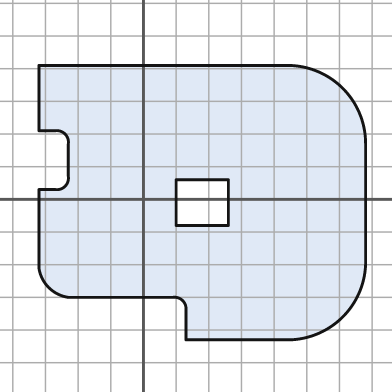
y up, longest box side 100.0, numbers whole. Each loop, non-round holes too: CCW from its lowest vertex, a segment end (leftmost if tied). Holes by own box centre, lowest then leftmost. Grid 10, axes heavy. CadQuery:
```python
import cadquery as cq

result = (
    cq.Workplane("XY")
    .moveTo(13.0, -43.0)
    .lineTo(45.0, -43.0)
    .threePointArc((61.0, -36.0), (68.0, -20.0))
    .lineTo(68.0, 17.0)
    .threePointArc((61.0, 34.0), (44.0, 41.0))
    .lineTo(-32.0, 41.0)
    .lineTo(-32.0, 21.0)
    .lineTo(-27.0, 21.0)
    .threePointArc((-24.0, 20.0), (-23.0, 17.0))
    .lineTo(-23.0, 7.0)
    .threePointArc((-24.0, 4.0), (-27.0, 3.0))
    .lineTo(-32.0, 3.0)
    .lineTo(-32.0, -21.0)
    .threePointArc((-29.0, -27.0), (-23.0, -30.0))
    .lineTo(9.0, -30.0)
    .threePointArc((12.0, -31.0), (13.0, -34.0))
    .close()
    .moveTo(10.0, -8.0)
    .lineTo(26.0, -8.0)
    .lineTo(26.0, 6.0)
    .lineTo(10.0, 6.0)
    .close()
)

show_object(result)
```